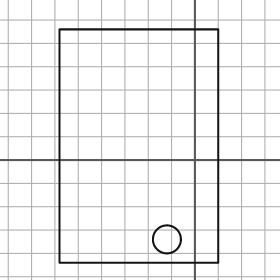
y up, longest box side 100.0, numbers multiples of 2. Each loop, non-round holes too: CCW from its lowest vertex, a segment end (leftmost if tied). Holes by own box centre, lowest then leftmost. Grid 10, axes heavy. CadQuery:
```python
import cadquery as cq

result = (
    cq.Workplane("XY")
    .moveTo(-58.0, -44.0)
    .lineTo(10.0, -44.0)
    .lineTo(10.0, 56.0)
    .lineTo(-58.0, 56.0)
    .close()
    .moveTo(-12.0, -34.0)
    .circle(6.0)
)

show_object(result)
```